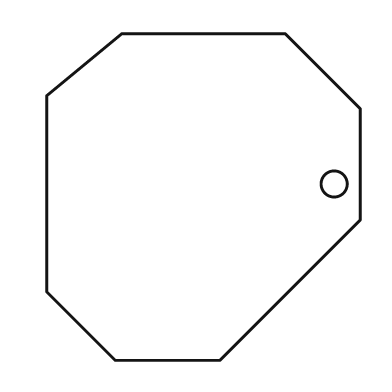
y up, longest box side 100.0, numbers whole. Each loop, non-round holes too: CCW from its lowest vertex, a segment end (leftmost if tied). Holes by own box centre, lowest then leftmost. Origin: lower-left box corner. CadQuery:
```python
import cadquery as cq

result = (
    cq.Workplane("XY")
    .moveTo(21.0, 0.0)
    .lineTo(53.0, 0.0)
    .lineTo(96.0, 43.0)
    .lineTo(96.0, 77.0)
    .lineTo(73.0, 100.0)
    .lineTo(23.0, 100.0)
    .lineTo(0.0, 81.0)
    .lineTo(0.0, 21.0)
    .close()
    .moveTo(88.0, 54.0)
    .circle(4.0)
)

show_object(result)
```